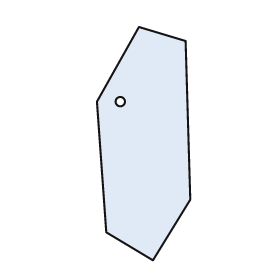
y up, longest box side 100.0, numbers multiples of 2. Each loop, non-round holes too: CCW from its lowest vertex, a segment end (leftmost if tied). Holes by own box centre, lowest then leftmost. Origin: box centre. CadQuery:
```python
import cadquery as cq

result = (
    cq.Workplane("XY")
    .moveTo(4.0, -50.0)
    .lineTo(20.0, -24.0)
    .lineTo(18.0, 44.0)
    .lineTo(-2.0, 50.0)
    .lineTo(-20.0, 18.0)
    .lineTo(-16.0, -38.0)
    .close()
    .moveTo(-10.0, 18.0)
    .circle(2.0)
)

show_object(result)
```